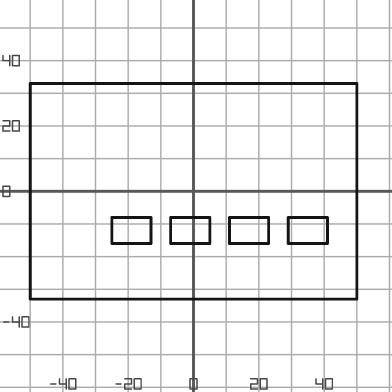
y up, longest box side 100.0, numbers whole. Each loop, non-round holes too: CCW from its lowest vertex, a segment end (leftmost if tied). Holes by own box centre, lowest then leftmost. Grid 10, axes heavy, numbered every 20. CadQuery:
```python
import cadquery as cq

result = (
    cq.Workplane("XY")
    .moveTo(-50.0, -33.0)
    .lineTo(50.0, -33.0)
    .lineTo(50.0, 33.0)
    .lineTo(-50.0, 33.0)
    .close()
    .moveTo(-25.0, -16.0)
    .lineTo(-13.0, -16.0)
    .lineTo(-13.0, -8.0)
    .lineTo(-25.0, -8.0)
    .close()
    .moveTo(-7.0, -16.0)
    .lineTo(5.0, -16.0)
    .lineTo(5.0, -8.0)
    .lineTo(-7.0, -8.0)
    .close()
    .moveTo(11.0, -16.0)
    .lineTo(23.0, -16.0)
    .lineTo(23.0, -8.0)
    .lineTo(11.0, -8.0)
    .close()
    .moveTo(29.0, -16.0)
    .lineTo(41.0, -16.0)
    .lineTo(41.0, -8.0)
    .lineTo(29.0, -8.0)
    .close()
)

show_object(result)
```